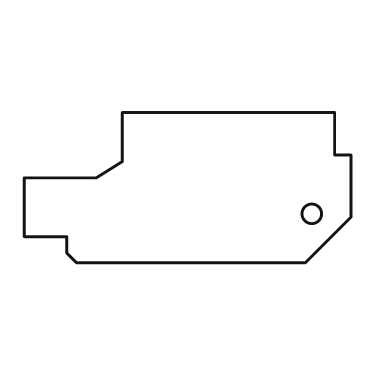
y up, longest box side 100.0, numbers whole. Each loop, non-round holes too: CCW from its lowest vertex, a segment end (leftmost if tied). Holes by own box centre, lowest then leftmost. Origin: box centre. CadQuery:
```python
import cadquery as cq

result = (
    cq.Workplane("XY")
    .moveTo(-34.0, -23.0)
    .lineTo(36.0, -23.0)
    .lineTo(50.0, -9.0)
    .lineTo(50.0, 10.0)
    .lineTo(45.0, 10.0)
    .lineTo(45.0, 23.0)
    .lineTo(-20.0, 23.0)
    .lineTo(-20.0, 8.0)
    .lineTo(-28.0, 3.0)
    .lineTo(-50.0, 3.0)
    .lineTo(-50.0, -15.0)
    .lineTo(-37.0, -15.0)
    .lineTo(-37.0, -20.0)
    .close()
    .moveTo(38.0, -8.0)
    .circle(3.0)
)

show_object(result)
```